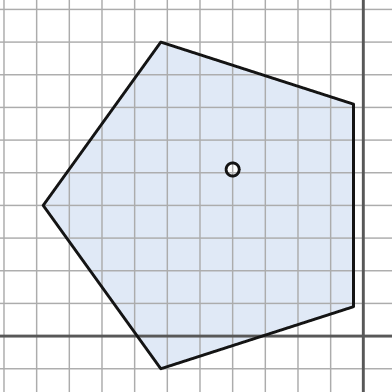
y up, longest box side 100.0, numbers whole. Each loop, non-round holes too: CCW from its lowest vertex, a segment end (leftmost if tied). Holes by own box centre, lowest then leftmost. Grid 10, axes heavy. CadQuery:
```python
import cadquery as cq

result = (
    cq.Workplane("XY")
    .moveTo(-62.0, -10.0)
    .lineTo(-3.0, 9.0)
    .lineTo(-3.0, 71.0)
    .lineTo(-62.0, 90.0)
    .lineTo(-98.0, 40.0)
    .close()
    .moveTo(-40.0, 51.0)
    .circle(2.0)
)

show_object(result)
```